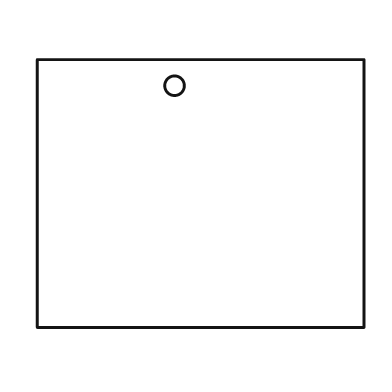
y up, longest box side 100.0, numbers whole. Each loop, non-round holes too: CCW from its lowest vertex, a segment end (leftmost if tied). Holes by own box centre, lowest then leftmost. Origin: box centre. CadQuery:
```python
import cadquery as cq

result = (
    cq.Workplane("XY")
    .moveTo(-50.0, -41.0)
    .lineTo(50.0, -41.0)
    .lineTo(50.0, 41.0)
    .lineTo(-50.0, 41.0)
    .close()
    .moveTo(-8.0, 33.0)
    .circle(3.0)
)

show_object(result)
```